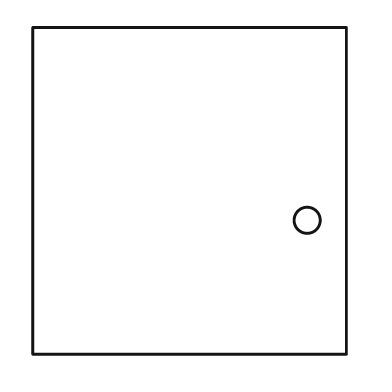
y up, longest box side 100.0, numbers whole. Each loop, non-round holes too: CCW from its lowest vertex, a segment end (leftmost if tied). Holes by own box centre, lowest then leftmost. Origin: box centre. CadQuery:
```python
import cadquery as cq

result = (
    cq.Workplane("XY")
    .moveTo(-48.0, -50.0)
    .lineTo(48.0, -50.0)
    .lineTo(48.0, 50.0)
    .lineTo(-48.0, 50.0)
    .close()
    .moveTo(36.0, -9.0)
    .circle(4.0)
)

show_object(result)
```